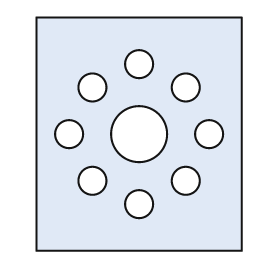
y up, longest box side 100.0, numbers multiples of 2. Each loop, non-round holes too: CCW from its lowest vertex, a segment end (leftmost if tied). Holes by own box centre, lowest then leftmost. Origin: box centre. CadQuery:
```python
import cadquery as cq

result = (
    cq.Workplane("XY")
    .moveTo(-44.0, -50.0)
    .lineTo(44.0, -50.0)
    .lineTo(44.0, 50.0)
    .lineTo(-44.0, 50.0)
    .close()
    .moveTo(0.0, -30.0)
    .circle(6.0)
    .moveTo(-20.0, -20.0)
    .circle(6.0)
    .moveTo(20.0, -20.0)
    .circle(6.0)
    .moveTo(-30.0, 0.0)
    .circle(6.0)
    .moveTo(0.0, 0.0)
    .circle(12.0)
    .moveTo(30.0, 0.0)
    .circle(6.0)
    .moveTo(-20.0, 20.0)
    .circle(6.0)
    .moveTo(20.0, 20.0)
    .circle(6.0)
    .moveTo(0.0, 30.0)
    .circle(6.0)
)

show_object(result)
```